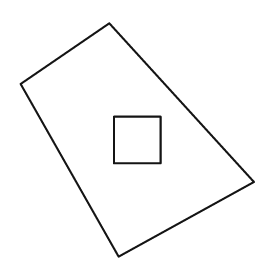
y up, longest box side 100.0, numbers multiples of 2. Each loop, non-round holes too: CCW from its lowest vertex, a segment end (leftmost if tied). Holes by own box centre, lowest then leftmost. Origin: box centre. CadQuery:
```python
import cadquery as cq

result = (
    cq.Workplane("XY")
    .moveTo(-8.0, -50.0)
    .lineTo(50.0, -18.0)
    .lineTo(-12.0, 50.0)
    .lineTo(-50.0, 24.0)
    .close()
    .moveTo(-10.0, -10.0)
    .lineTo(10.0, -10.0)
    .lineTo(10.0, 10.0)
    .lineTo(-10.0, 10.0)
    .close()
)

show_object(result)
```